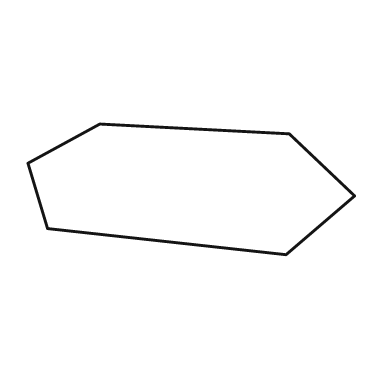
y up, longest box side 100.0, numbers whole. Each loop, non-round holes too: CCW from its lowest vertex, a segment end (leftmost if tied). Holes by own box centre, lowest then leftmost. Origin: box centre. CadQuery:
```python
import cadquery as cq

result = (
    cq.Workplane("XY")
    .moveTo(29.0, -20.0)
    .lineTo(50.0, -2.0)
    .lineTo(30.0, 17.0)
    .lineTo(-28.0, 20.0)
    .lineTo(-50.0, 8.0)
    .lineTo(-44.0, -12.0)
    .close()
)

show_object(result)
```